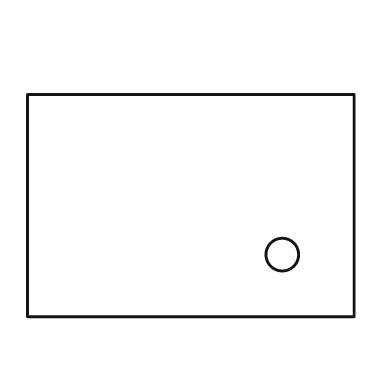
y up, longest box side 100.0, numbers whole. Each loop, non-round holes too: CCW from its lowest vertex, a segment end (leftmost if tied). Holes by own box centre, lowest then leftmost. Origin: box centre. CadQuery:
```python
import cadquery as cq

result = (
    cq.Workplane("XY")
    .moveTo(-50.0, -34.0)
    .lineTo(50.0, -34.0)
    .lineTo(50.0, 34.0)
    .lineTo(-50.0, 34.0)
    .close()
    .moveTo(28.0, -15.0)
    .circle(5.0)
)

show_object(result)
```